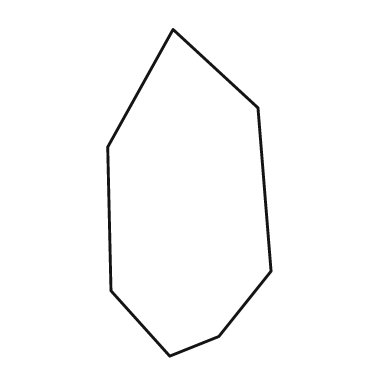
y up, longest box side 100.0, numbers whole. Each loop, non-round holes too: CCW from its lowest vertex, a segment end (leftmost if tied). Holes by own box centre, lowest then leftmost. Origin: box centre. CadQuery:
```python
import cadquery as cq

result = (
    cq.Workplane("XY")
    .moveTo(-6.0, -50.0)
    .lineTo(9.0, -44.0)
    .lineTo(25.0, -24.0)
    .lineTo(21.0, 26.0)
    .lineTo(-5.0, 50.0)
    .lineTo(-25.0, 14.0)
    .lineTo(-24.0, -30.0)
    .close()
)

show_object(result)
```